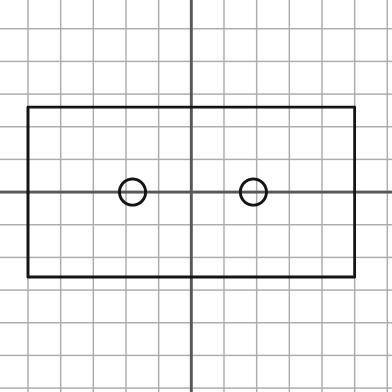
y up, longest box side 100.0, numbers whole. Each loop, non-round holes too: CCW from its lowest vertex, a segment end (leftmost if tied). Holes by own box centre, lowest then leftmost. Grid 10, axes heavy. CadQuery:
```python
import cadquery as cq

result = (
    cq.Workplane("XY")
    .moveTo(-50.0, -26.0)
    .lineTo(50.0, -26.0)
    .lineTo(50.0, 26.0)
    .lineTo(-50.0, 26.0)
    .close()
    .moveTo(-18.0, 0.0)
    .circle(4.0)
    .moveTo(19.0, 0.0)
    .circle(4.0)
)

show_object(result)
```